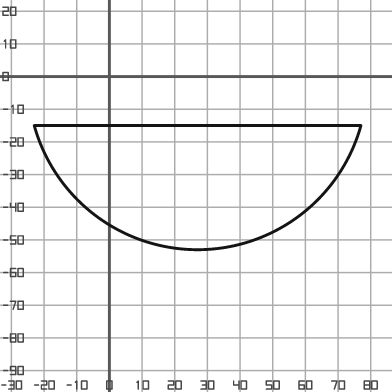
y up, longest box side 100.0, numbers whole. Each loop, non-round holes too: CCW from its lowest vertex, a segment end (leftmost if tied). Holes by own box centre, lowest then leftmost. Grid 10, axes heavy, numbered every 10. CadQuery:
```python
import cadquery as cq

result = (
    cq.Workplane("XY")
    .moveTo(-23.0, -15.0)
    .threePointArc((27.0, -53.0), (77.0, -15.0))
    .close()
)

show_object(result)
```